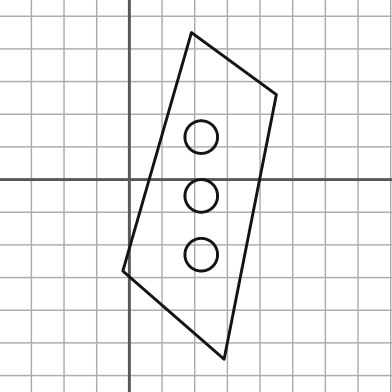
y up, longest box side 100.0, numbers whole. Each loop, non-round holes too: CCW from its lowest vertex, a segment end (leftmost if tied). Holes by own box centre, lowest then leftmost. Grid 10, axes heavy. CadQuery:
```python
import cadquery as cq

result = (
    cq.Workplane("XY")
    .moveTo(29.0, -55.0)
    .lineTo(45.0, 26.0)
    .lineTo(19.0, 45.0)
    .lineTo(-2.0, -28.0)
    .close()
    .moveTo(22.0, -23.0)
    .circle(5.0)
    .moveTo(22.0, -5.0)
    .circle(5.0)
    .moveTo(22.0, 13.0)
    .circle(5.0)
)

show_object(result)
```